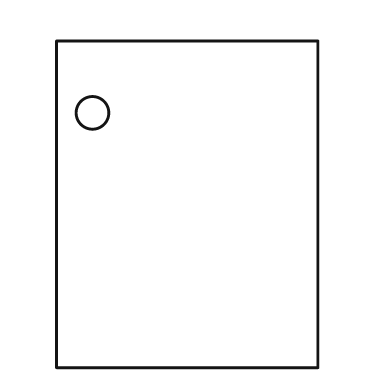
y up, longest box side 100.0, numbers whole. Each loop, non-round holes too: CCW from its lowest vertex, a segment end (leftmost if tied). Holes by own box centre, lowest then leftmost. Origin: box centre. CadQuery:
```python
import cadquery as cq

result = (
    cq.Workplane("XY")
    .moveTo(-40.0, -50.0)
    .lineTo(40.0, -50.0)
    .lineTo(40.0, 50.0)
    .lineTo(-40.0, 50.0)
    .close()
    .moveTo(-29.0, 28.0)
    .circle(5.0)
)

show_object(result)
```